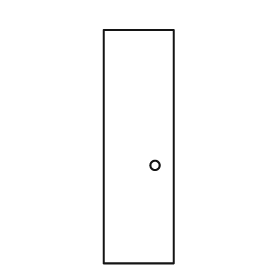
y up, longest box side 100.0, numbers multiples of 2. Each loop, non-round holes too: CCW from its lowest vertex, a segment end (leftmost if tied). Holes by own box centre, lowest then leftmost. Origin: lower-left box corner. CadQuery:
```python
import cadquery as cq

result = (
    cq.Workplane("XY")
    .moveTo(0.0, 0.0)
    .lineTo(30.0, 0.0)
    .lineTo(30.0, 100.0)
    .lineTo(0.0, 100.0)
    .close()
    .moveTo(22.0, 42.0)
    .circle(2.0)
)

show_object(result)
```